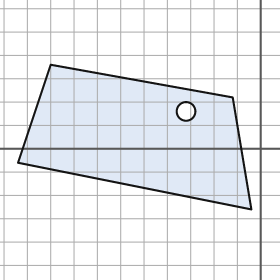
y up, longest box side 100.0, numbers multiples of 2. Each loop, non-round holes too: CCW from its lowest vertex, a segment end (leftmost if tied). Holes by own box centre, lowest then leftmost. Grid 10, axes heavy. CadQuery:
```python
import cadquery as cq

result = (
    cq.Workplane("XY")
    .moveTo(-4.0, -26.0)
    .lineTo(-12.0, 22.0)
    .lineTo(-90.0, 36.0)
    .lineTo(-104.0, -6.0)
    .close()
    .moveTo(-32.0, 16.0)
    .circle(4.0)
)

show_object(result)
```